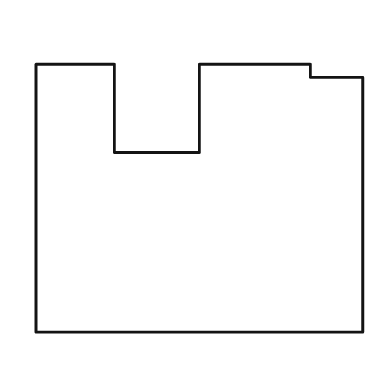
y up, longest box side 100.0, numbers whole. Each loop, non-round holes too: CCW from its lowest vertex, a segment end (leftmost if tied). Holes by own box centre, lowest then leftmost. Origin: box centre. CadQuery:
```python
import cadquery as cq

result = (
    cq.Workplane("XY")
    .moveTo(-50.0, -41.0)
    .lineTo(50.0, -41.0)
    .lineTo(50.0, 37.0)
    .lineTo(34.0, 37.0)
    .lineTo(34.0, 41.0)
    .lineTo(0.0, 41.0)
    .lineTo(0.0, 14.0)
    .lineTo(-26.0, 14.0)
    .lineTo(-26.0, 41.0)
    .lineTo(-50.0, 41.0)
    .close()
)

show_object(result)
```